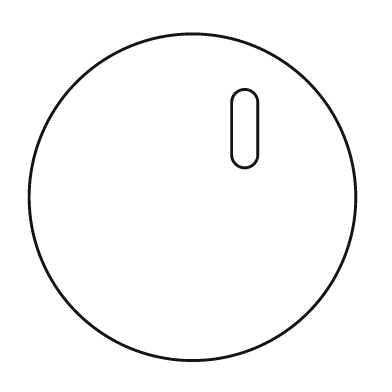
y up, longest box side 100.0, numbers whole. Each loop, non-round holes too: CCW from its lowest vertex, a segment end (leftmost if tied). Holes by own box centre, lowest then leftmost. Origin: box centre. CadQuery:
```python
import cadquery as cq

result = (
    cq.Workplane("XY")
    .moveTo(0.0, 0.0)
    .circle(50.0)
    .moveTo(12.0, 13.0)
    .threePointArc((16.0, 9.0), (20.0, 13.0))
    .lineTo(20.0, 29.0)
    .threePointArc((16.0, 33.0), (12.0, 29.0))
    .close()
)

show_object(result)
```